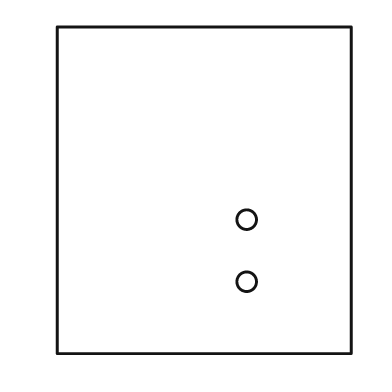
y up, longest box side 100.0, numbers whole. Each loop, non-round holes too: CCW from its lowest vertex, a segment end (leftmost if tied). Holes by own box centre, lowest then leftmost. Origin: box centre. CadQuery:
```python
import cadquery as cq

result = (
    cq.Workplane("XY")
    .moveTo(-45.0, -50.0)
    .lineTo(45.0, -50.0)
    .lineTo(45.0, 50.0)
    .lineTo(-45.0, 50.0)
    .close()
    .moveTo(13.0, -28.0)
    .circle(3.0)
    .moveTo(13.0, -9.0)
    .circle(3.0)
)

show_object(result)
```